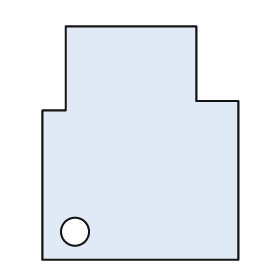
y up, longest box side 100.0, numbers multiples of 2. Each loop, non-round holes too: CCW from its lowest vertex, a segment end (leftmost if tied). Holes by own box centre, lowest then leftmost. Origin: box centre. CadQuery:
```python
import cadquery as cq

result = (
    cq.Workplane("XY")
    .moveTo(-42.0, -50.0)
    .lineTo(42.0, -50.0)
    .lineTo(42.0, 18.0)
    .lineTo(24.0, 18.0)
    .lineTo(24.0, 50.0)
    .lineTo(-32.0, 50.0)
    .lineTo(-32.0, 14.0)
    .lineTo(-42.0, 14.0)
    .close()
    .moveTo(-28.0, -38.0)
    .circle(6.0)
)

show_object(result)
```